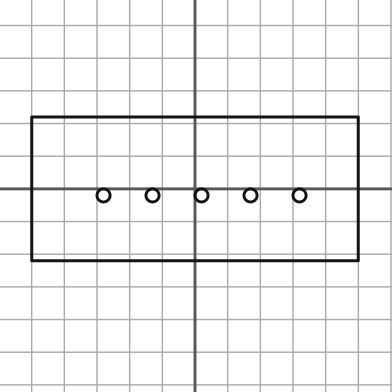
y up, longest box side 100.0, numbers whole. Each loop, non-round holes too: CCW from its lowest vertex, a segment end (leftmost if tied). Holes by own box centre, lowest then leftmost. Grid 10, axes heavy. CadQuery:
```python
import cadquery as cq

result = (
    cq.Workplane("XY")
    .moveTo(-50.0, -22.0)
    .lineTo(50.0, -22.0)
    .lineTo(50.0, 22.0)
    .lineTo(-50.0, 22.0)
    .close()
    .moveTo(-28.0, -2.0)
    .circle(2.0)
    .moveTo(-13.0, -2.0)
    .circle(2.0)
    .moveTo(2.0, -2.0)
    .circle(2.0)
    .moveTo(17.0, -2.0)
    .circle(2.0)
    .moveTo(32.0, -2.0)
    .circle(2.0)
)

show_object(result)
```